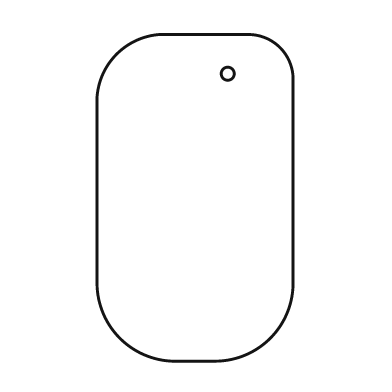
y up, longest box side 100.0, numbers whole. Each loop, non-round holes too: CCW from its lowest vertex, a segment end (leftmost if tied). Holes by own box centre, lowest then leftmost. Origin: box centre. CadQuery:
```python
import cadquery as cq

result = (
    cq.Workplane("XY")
    .moveTo(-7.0, -50.0)
    .lineTo(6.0, -50.0)
    .threePointArc((23.0, -43.0), (30.0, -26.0))
    .lineTo(30.0, 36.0)
    .threePointArc((26.0, 46.0), (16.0, 50.0))
    .lineTo(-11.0, 50.0)
    .threePointArc((-24.0, 44.0), (-30.0, 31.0))
    .lineTo(-30.0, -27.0)
    .threePointArc((-23.0, -43.0), (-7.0, -50.0))
    .close()
    .moveTo(10.0, 38.0)
    .circle(2.0)
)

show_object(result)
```